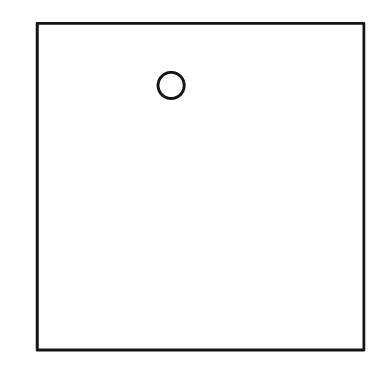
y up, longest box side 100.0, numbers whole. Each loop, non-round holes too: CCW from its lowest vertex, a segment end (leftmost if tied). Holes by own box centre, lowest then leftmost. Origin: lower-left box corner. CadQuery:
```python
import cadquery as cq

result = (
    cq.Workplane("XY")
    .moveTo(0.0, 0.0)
    .lineTo(100.0, 0.0)
    .lineTo(100.0, 100.0)
    .lineTo(0.0, 100.0)
    .close()
    .moveTo(41.0, 81.0)
    .circle(4.0)
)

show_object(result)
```